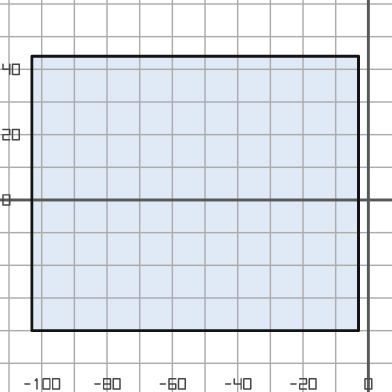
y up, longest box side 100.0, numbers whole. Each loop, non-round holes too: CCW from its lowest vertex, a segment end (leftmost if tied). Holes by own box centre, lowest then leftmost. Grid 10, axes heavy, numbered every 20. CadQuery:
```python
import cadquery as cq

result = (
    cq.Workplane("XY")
    .moveTo(-103.0, -40.0)
    .lineTo(-3.0, -40.0)
    .lineTo(-3.0, 44.0)
    .lineTo(-103.0, 44.0)
    .close()
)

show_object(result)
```